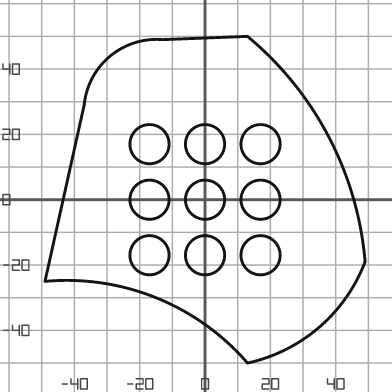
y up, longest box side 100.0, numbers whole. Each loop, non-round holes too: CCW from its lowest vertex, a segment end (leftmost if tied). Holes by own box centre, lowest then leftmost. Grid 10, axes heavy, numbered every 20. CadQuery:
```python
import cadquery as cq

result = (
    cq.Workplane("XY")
    .moveTo(13.0, -50.0)
    .threePointArc((35.0, -39.0), (49.0, -19.0))
    .threePointArc((38.0, 19.0), (13.0, 50.0))
    .lineTo(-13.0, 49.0)
    .threePointArc((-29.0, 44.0), (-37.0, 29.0))
    .lineTo(-49.0, -25.0)
    .threePointArc((-15.0, -30.0), (13.0, -50.0))
    .close()
    .moveTo(-17.0, -17.0)
    .circle(6.0)
    .moveTo(0.0, -17.0)
    .circle(6.0)
    .moveTo(17.0, -17.0)
    .circle(6.0)
    .moveTo(-17.0, 0.0)
    .circle(6.0)
    .moveTo(0.0, 0.0)
    .circle(6.0)
    .moveTo(17.0, 0.0)
    .circle(6.0)
    .moveTo(-17.0, 17.0)
    .circle(6.0)
    .moveTo(0.0, 17.0)
    .circle(6.0)
    .moveTo(17.0, 17.0)
    .circle(6.0)
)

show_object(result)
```